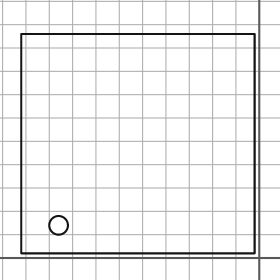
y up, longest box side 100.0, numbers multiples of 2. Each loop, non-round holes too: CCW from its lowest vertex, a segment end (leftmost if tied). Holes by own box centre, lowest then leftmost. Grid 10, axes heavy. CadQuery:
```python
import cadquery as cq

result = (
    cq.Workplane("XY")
    .moveTo(-102.0, 2.0)
    .lineTo(-2.0, 2.0)
    .lineTo(-2.0, 96.0)
    .lineTo(-102.0, 96.0)
    .close()
    .moveTo(-86.0, 14.0)
    .circle(4.0)
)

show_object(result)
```